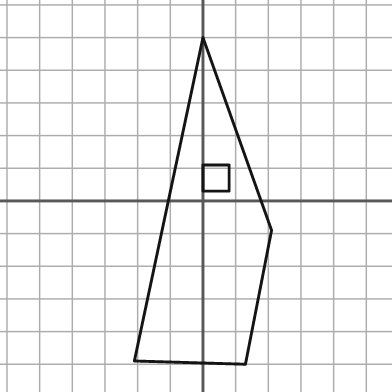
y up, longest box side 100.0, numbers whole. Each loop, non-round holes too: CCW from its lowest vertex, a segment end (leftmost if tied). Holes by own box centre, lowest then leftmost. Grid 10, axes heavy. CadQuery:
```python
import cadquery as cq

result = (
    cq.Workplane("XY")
    .moveTo(13.0, -50.0)
    .lineTo(21.0, -9.0)
    .lineTo(0.0, 50.0)
    .lineTo(-21.0, -49.0)
    .close()
    .moveTo(0.0, 3.0)
    .lineTo(8.0, 3.0)
    .lineTo(8.0, 11.0)
    .lineTo(0.0, 11.0)
    .close()
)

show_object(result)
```